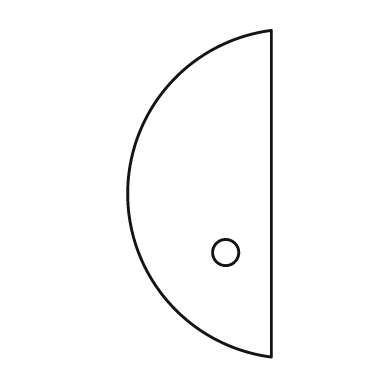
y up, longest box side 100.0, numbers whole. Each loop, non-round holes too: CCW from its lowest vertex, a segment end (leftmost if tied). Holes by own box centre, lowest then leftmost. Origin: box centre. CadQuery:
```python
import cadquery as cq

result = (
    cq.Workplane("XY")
    .moveTo(22.0, -50.0)
    .lineTo(22.0, 50.0)
    .threePointArc((-22.0, 0.0), (22.0, -50.0))
    .close()
    .moveTo(8.0, -18.0)
    .circle(4.0)
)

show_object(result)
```